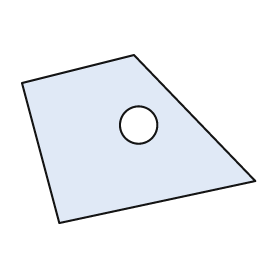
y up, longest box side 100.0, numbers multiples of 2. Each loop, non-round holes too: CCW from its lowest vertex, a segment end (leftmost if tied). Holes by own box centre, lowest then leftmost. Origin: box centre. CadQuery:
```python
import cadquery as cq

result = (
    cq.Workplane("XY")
    .moveTo(-34.0, -36.0)
    .lineTo(50.0, -18.0)
    .lineTo(-2.0, 36.0)
    .lineTo(-50.0, 24.0)
    .close()
    .moveTo(0.0, 6.0)
    .circle(8.0)
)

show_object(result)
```